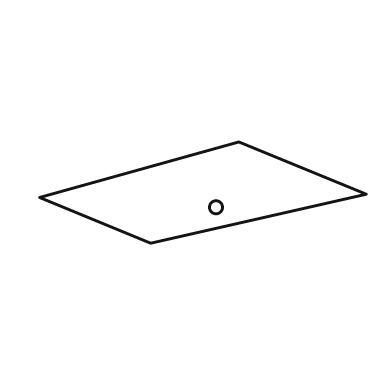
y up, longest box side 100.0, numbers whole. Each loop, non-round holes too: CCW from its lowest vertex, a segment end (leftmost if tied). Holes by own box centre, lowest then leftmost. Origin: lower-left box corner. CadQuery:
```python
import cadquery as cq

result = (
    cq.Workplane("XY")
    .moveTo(34.0, 0.0)
    .lineTo(100.0, 15.0)
    .lineTo(61.0, 31.0)
    .lineTo(0.0, 14.0)
    .close()
    .moveTo(54.0, 11.0)
    .circle(2.0)
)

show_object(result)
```